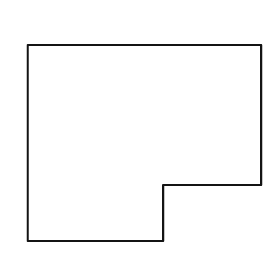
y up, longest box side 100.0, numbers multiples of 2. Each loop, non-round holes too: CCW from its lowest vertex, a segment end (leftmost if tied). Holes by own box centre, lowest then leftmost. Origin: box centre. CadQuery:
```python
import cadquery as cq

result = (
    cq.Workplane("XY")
    .moveTo(-50.0, -42.0)
    .lineTo(8.0, -42.0)
    .lineTo(8.0, -18.0)
    .lineTo(50.0, -18.0)
    .lineTo(50.0, 42.0)
    .lineTo(-50.0, 42.0)
    .close()
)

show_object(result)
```